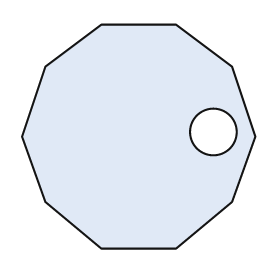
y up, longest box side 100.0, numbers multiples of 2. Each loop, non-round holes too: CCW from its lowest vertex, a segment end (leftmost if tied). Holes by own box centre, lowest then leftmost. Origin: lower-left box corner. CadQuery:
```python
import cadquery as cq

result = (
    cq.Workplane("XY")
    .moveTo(34.0, 0.0)
    .lineTo(66.0, 0.0)
    .lineTo(90.0, 20.0)
    .lineTo(100.0, 48.0)
    .lineTo(90.0, 78.0)
    .lineTo(66.0, 96.0)
    .lineTo(34.0, 96.0)
    .lineTo(10.0, 78.0)
    .lineTo(0.0, 48.0)
    .lineTo(10.0, 20.0)
    .close()
    .moveTo(82.0, 50.0)
    .circle(10.0)
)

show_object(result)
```